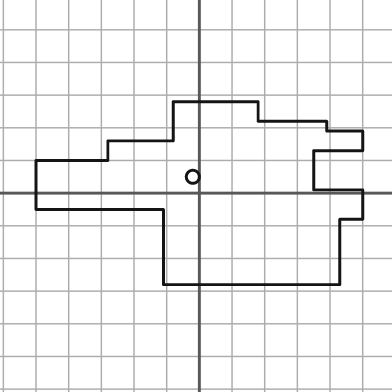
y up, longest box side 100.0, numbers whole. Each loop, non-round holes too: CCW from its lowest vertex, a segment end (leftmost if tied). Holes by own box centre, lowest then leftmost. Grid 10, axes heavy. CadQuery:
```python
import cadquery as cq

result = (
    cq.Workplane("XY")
    .moveTo(-11.0, -28.0)
    .lineTo(43.0, -28.0)
    .lineTo(43.0, -8.0)
    .lineTo(50.0, -8.0)
    .lineTo(50.0, 1.0)
    .lineTo(35.0, 1.0)
    .lineTo(35.0, 13.0)
    .lineTo(50.0, 13.0)
    .lineTo(50.0, 19.0)
    .lineTo(39.0, 19.0)
    .lineTo(39.0, 22.0)
    .lineTo(18.0, 22.0)
    .lineTo(18.0, 28.0)
    .lineTo(-8.0, 28.0)
    .lineTo(-8.0, 16.0)
    .lineTo(-28.0, 16.0)
    .lineTo(-28.0, 10.0)
    .lineTo(-50.0, 10.0)
    .lineTo(-50.0, -5.0)
    .lineTo(-11.0, -5.0)
    .close()
    .moveTo(-2.0, 5.0)
    .circle(2.0)
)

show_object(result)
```